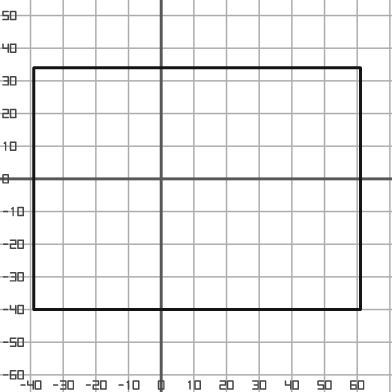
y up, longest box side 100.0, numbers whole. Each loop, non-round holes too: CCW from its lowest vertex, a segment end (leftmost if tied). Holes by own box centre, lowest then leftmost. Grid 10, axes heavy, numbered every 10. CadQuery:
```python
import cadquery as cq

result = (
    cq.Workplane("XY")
    .moveTo(-39.0, -40.0)
    .lineTo(61.0, -40.0)
    .lineTo(61.0, 34.0)
    .lineTo(-39.0, 34.0)
    .close()
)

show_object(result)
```